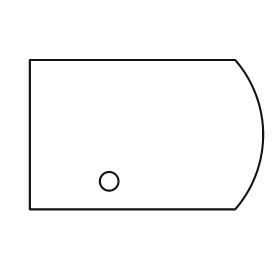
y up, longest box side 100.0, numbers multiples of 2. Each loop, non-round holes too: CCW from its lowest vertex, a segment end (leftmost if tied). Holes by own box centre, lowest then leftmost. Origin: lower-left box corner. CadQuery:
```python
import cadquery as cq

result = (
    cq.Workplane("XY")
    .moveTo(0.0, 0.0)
    .lineTo(88.0, 0.0)
    .threePointArc((100.0, 32.0), (88.0, 64.0))
    .lineTo(0.0, 64.0)
    .close()
    .moveTo(34.0, 12.0)
    .circle(4.0)
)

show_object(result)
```